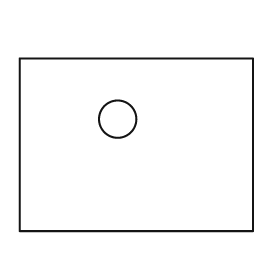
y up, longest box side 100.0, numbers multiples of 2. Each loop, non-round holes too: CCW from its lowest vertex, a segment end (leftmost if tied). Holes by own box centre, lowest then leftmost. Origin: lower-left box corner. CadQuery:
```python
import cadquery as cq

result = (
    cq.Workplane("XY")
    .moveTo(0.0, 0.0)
    .lineTo(100.0, 0.0)
    .lineTo(100.0, 74.0)
    .lineTo(0.0, 74.0)
    .close()
    .moveTo(42.0, 48.0)
    .circle(8.0)
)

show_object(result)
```